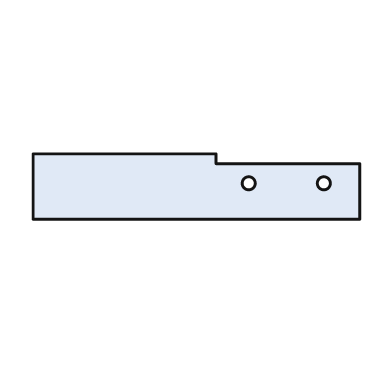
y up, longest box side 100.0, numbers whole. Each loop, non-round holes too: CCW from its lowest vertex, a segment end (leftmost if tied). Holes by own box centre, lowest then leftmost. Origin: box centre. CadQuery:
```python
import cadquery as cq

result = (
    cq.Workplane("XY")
    .moveTo(-50.0, -10.0)
    .lineTo(50.0, -10.0)
    .lineTo(50.0, 7.0)
    .lineTo(6.0, 7.0)
    .lineTo(6.0, 10.0)
    .lineTo(-50.0, 10.0)
    .close()
    .moveTo(16.0, 1.0)
    .circle(2.0)
    .moveTo(39.0, 1.0)
    .circle(2.0)
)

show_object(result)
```